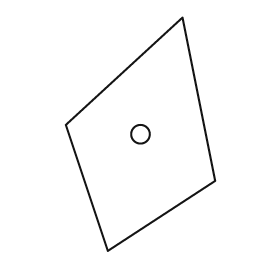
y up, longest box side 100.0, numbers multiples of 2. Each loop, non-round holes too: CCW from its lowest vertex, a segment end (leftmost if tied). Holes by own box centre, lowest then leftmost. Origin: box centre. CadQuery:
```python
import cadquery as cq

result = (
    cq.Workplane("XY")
    .moveTo(-14.0, -50.0)
    .lineTo(32.0, -20.0)
    .lineTo(18.0, 50.0)
    .lineTo(-32.0, 4.0)
    .close()
    .moveTo(0.0, 0.0)
    .circle(4.0)
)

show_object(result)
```